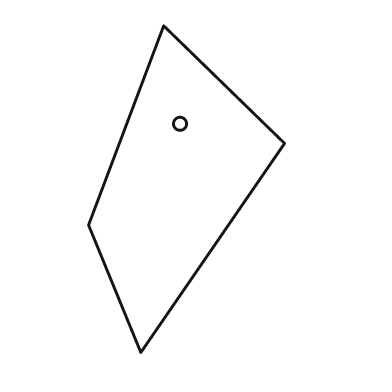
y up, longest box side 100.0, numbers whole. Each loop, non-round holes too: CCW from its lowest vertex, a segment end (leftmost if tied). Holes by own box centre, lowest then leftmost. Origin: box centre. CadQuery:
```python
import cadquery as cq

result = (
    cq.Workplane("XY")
    .moveTo(-14.0, -50.0)
    .lineTo(30.0, 14.0)
    .lineTo(-7.0, 50.0)
    .lineTo(-30.0, -11.0)
    .close()
    .moveTo(-2.0, 20.0)
    .circle(2.0)
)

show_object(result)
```